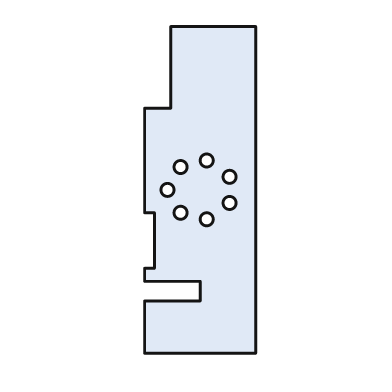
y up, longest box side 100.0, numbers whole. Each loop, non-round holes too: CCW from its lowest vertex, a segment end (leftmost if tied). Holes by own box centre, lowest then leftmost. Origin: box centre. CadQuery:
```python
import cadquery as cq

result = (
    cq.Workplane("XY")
    .moveTo(-17.0, -50.0)
    .lineTo(17.0, -50.0)
    .lineTo(17.0, 50.0)
    .lineTo(-9.0, 50.0)
    .lineTo(-9.0, 25.0)
    .lineTo(-17.0, 25.0)
    .lineTo(-17.0, -7.0)
    .lineTo(-14.0, -7.0)
    .lineTo(-14.0, -24.0)
    .lineTo(-17.0, -24.0)
    .lineTo(-17.0, -28.0)
    .lineTo(0.0, -28.0)
    .lineTo(0.0, -34.0)
    .lineTo(-17.0, -34.0)
    .close()
    .moveTo(2.0, -9.0)
    .circle(2.0)
    .moveTo(-6.0, -7.0)
    .circle(2.0)
    .moveTo(9.0, -4.0)
    .circle(2.0)
    .moveTo(-10.0, 0.0)
    .circle(2.0)
    .moveTo(9.0, 4.0)
    .circle(2.0)
    .moveTo(-6.0, 7.0)
    .circle(2.0)
    .moveTo(2.0, 9.0)
    .circle(2.0)
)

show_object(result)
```